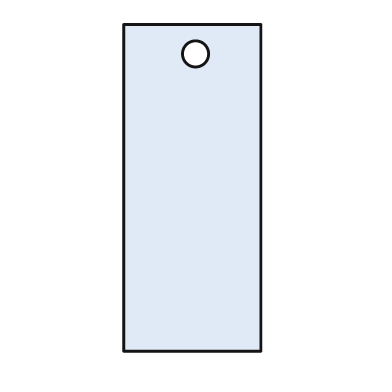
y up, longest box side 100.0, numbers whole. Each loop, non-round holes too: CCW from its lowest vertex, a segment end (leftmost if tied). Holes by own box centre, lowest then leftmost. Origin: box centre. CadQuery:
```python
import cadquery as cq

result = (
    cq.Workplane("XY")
    .moveTo(-21.0, -50.0)
    .lineTo(21.0, -50.0)
    .lineTo(21.0, 50.0)
    .lineTo(-21.0, 50.0)
    .close()
    .moveTo(1.0, 41.0)
    .circle(4.0)
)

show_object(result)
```